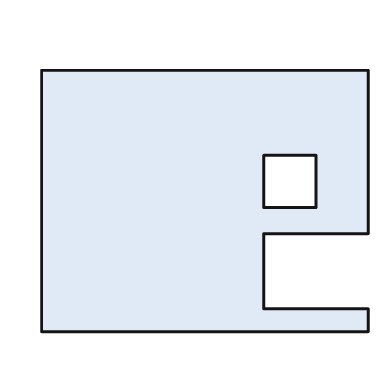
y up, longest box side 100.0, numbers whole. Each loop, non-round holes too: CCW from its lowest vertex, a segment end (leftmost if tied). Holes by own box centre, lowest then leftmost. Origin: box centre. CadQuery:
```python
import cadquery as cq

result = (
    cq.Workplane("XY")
    .moveTo(-50.0, -40.0)
    .lineTo(50.0, -40.0)
    .lineTo(50.0, -33.0)
    .lineTo(18.0, -33.0)
    .lineTo(18.0, -10.0)
    .lineTo(50.0, -10.0)
    .lineTo(50.0, 40.0)
    .lineTo(-50.0, 40.0)
    .close()
    .moveTo(18.0, -2.0)
    .lineTo(34.0, -2.0)
    .lineTo(34.0, 14.0)
    .lineTo(18.0, 14.0)
    .close()
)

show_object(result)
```